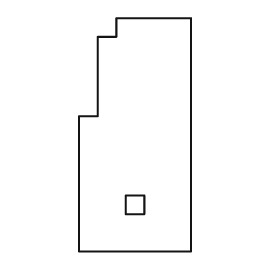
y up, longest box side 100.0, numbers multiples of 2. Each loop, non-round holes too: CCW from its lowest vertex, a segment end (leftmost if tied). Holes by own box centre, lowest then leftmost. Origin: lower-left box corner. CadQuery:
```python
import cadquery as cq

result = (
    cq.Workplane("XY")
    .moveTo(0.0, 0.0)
    .lineTo(48.0, 0.0)
    .lineTo(48.0, 100.0)
    .lineTo(16.0, 100.0)
    .lineTo(16.0, 92.0)
    .lineTo(8.0, 92.0)
    .lineTo(8.0, 58.0)
    .lineTo(0.0, 58.0)
    .close()
    .moveTo(20.0, 16.0)
    .lineTo(28.0, 16.0)
    .lineTo(28.0, 24.0)
    .lineTo(20.0, 24.0)
    .close()
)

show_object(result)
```